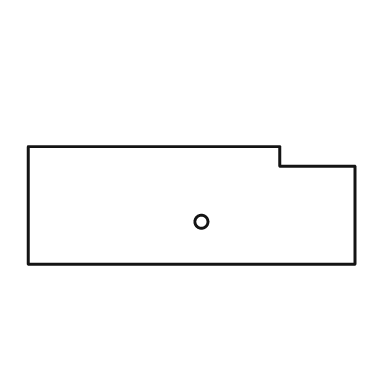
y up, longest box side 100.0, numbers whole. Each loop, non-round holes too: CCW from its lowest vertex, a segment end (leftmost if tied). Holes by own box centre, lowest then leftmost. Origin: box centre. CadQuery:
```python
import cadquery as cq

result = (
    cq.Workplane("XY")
    .moveTo(-50.0, -18.0)
    .lineTo(50.0, -18.0)
    .lineTo(50.0, 12.0)
    .lineTo(27.0, 12.0)
    .lineTo(27.0, 18.0)
    .lineTo(-50.0, 18.0)
    .close()
    .moveTo(3.0, -5.0)
    .circle(2.0)
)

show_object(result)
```